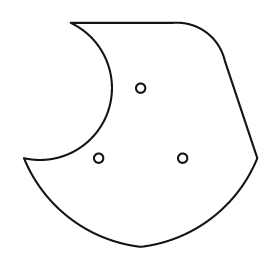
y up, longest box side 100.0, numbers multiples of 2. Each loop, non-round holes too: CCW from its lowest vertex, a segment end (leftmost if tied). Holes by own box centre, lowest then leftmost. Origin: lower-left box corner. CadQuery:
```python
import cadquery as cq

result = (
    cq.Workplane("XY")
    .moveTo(50.0, 0.0)
    .threePointArc((80.0, 12.0), (100.0, 38.0))
    .lineTo(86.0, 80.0)
    .threePointArc((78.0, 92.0), (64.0, 96.0))
    .lineTo(20.0, 96.0)
    .threePointArc((36.0, 58.0), (0.0, 38.0))
    .threePointArc((20.0, 12.0), (50.0, 0.0))
    .close()
    .moveTo(32.0, 38.0)
    .circle(2.0)
    .moveTo(68.0, 38.0)
    .circle(2.0)
    .moveTo(50.0, 68.0)
    .circle(2.0)
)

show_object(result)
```